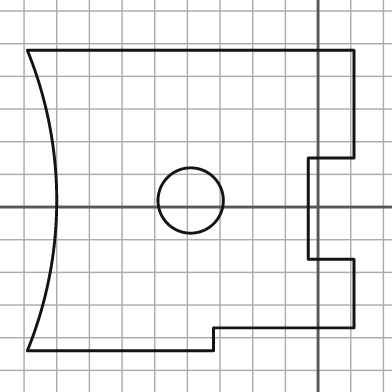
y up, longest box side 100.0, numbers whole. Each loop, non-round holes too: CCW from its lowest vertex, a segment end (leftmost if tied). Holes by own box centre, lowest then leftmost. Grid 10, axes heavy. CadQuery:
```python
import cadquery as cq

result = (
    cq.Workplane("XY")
    .moveTo(-89.0, -44.0)
    .lineTo(-32.0, -44.0)
    .lineTo(-32.0, -37.0)
    .lineTo(11.0, -37.0)
    .lineTo(11.0, -16.0)
    .lineTo(-3.0, -16.0)
    .lineTo(-3.0, 15.0)
    .lineTo(11.0, 15.0)
    .lineTo(11.0, 48.0)
    .lineTo(-89.0, 48.0)
    .threePointArc((-80.0, 2.0), (-89.0, -44.0))
    .close()
    .moveTo(-39.0, 2.0)
    .circle(10.0)
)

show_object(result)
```